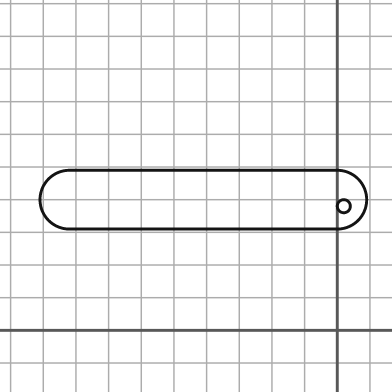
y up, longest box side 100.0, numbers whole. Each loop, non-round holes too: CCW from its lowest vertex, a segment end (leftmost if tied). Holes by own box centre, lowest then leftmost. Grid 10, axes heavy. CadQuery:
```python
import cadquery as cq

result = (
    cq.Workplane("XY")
    .moveTo(-82.0, 31.0)
    .lineTo(0.0, 31.0)
    .threePointArc((9.0, 40.0), (0.0, 49.0))
    .lineTo(-82.0, 49.0)
    .threePointArc((-91.0, 40.0), (-82.0, 31.0))
    .close()
    .moveTo(2.0, 38.0)
    .circle(2.0)
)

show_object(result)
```